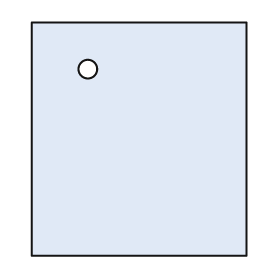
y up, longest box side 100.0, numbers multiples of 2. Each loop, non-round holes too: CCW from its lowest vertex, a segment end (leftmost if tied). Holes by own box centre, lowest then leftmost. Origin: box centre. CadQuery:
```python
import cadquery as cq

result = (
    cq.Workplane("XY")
    .moveTo(-46.0, -50.0)
    .lineTo(46.0, -50.0)
    .lineTo(46.0, 50.0)
    .lineTo(-46.0, 50.0)
    .close()
    .moveTo(-22.0, 30.0)
    .circle(4.0)
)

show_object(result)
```